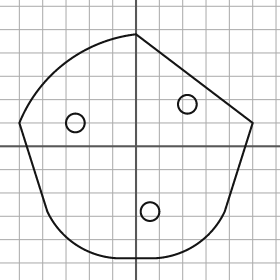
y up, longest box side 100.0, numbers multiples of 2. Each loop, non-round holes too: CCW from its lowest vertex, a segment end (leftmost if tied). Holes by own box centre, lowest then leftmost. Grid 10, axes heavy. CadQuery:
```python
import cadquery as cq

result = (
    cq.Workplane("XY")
    .moveTo(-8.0, -48.0)
    .lineTo(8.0, -48.0)
    .threePointArc((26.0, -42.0), (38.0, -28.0))
    .lineTo(50.0, 10.0)
    .lineTo(0.0, 48.0)
    .threePointArc((-30.0, 36.0), (-50.0, 10.0))
    .lineTo(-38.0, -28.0)
    .threePointArc((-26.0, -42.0), (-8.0, -48.0))
    .close()
    .moveTo(6.0, -28.0)
    .circle(4.0)
    .moveTo(-26.0, 10.0)
    .circle(4.0)
    .moveTo(22.0, 18.0)
    .circle(4.0)
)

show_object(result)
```